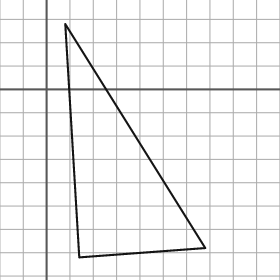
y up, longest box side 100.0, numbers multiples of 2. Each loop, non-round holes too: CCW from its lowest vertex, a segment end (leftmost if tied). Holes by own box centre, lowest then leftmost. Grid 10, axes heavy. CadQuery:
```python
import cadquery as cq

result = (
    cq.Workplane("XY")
    .moveTo(14.0, -72.0)
    .lineTo(68.0, -68.0)
    .lineTo(8.0, 28.0)
    .close()
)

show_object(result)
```